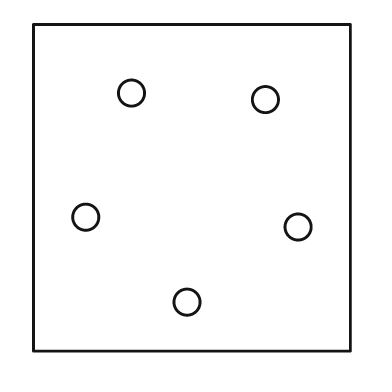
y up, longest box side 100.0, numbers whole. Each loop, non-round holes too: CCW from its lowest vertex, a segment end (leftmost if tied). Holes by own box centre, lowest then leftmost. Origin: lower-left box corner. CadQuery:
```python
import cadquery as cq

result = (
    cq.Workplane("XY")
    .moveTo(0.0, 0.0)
    .lineTo(97.0, 0.0)
    .lineTo(97.0, 100.0)
    .lineTo(0.0, 100.0)
    .close()
    .moveTo(47.0, 15.0)
    .circle(4.0)
    .moveTo(81.0, 38.0)
    .circle(4.0)
    .moveTo(16.0, 41.0)
    .circle(4.0)
    .moveTo(71.0, 77.0)
    .circle(4.0)
    .moveTo(30.0, 79.0)
    .circle(4.0)
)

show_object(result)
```